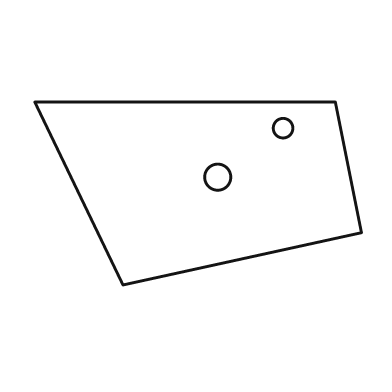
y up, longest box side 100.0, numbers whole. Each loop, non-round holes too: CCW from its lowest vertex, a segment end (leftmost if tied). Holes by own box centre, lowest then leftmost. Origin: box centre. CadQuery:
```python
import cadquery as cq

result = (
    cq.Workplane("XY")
    .moveTo(-23.0, -28.0)
    .lineTo(50.0, -12.0)
    .lineTo(42.0, 28.0)
    .lineTo(-50.0, 28.0)
    .close()
    .moveTo(6.0, 5.0)
    .circle(4.0)
    .moveTo(26.0, 20.0)
    .circle(3.0)
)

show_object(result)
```